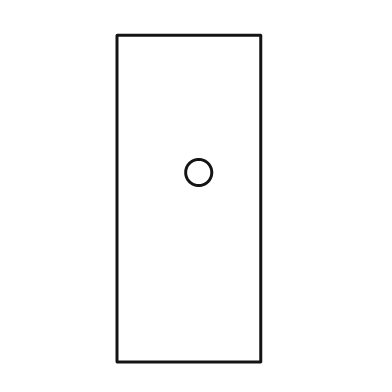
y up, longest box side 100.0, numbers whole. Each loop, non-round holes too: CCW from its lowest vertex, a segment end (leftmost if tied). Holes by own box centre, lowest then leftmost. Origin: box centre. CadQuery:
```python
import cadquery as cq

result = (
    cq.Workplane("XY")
    .moveTo(-22.0, -50.0)
    .lineTo(22.0, -50.0)
    .lineTo(22.0, 50.0)
    .lineTo(-22.0, 50.0)
    .close()
    .moveTo(3.0, 8.0)
    .circle(4.0)
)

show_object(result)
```